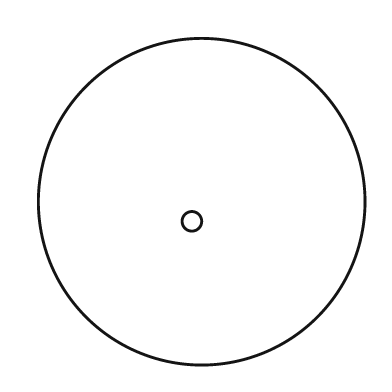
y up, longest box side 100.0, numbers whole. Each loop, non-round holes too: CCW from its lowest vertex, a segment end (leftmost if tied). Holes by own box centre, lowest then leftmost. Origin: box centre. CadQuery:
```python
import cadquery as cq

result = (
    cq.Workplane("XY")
    .moveTo(0.0, 0.0)
    .circle(50.0)
    .moveTo(-3.0, -6.0)
    .circle(3.0)
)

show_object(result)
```